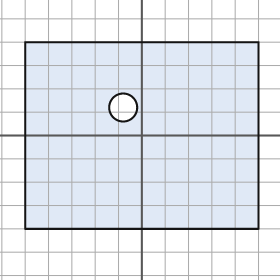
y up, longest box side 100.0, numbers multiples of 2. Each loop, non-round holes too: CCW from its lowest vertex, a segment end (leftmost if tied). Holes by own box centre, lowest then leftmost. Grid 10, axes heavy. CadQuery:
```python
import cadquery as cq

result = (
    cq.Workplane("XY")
    .moveTo(-50.0, -40.0)
    .lineTo(50.0, -40.0)
    .lineTo(50.0, 40.0)
    .lineTo(-50.0, 40.0)
    .close()
    .moveTo(-8.0, 12.0)
    .circle(6.0)
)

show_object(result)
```